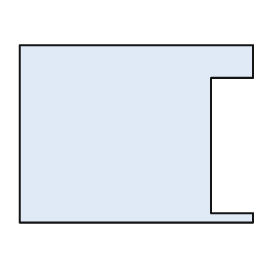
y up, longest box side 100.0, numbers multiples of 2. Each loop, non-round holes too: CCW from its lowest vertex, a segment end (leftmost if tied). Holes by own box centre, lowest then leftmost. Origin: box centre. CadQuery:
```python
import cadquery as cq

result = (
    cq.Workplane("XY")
    .moveTo(-50.0, -38.0)
    .lineTo(50.0, -38.0)
    .lineTo(50.0, -34.0)
    .lineTo(32.0, -34.0)
    .lineTo(32.0, 24.0)
    .lineTo(50.0, 24.0)
    .lineTo(50.0, 38.0)
    .lineTo(-50.0, 38.0)
    .close()
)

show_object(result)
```